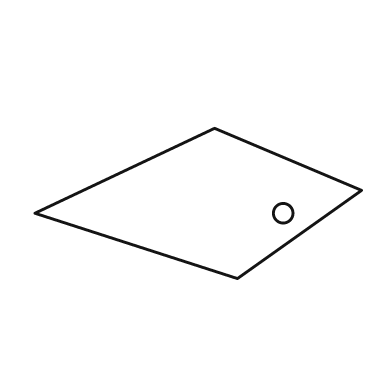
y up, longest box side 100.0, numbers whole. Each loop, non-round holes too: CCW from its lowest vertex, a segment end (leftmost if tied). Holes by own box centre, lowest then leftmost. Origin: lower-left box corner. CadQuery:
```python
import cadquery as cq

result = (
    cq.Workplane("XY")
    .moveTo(62.0, 0.0)
    .lineTo(100.0, 27.0)
    .lineTo(55.0, 46.0)
    .lineTo(0.0, 20.0)
    .close()
    .moveTo(76.0, 20.0)
    .circle(3.0)
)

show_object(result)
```